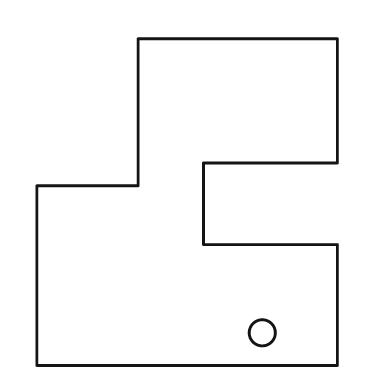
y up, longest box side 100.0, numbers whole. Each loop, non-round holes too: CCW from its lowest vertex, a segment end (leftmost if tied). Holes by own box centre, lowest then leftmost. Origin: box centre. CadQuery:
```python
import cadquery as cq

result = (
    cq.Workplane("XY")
    .moveTo(-46.0, -50.0)
    .lineTo(46.0, -50.0)
    .lineTo(46.0, -13.0)
    .lineTo(5.0, -13.0)
    .lineTo(5.0, 12.0)
    .lineTo(46.0, 12.0)
    .lineTo(46.0, 50.0)
    .lineTo(-15.0, 50.0)
    .lineTo(-15.0, 5.0)
    .lineTo(-46.0, 5.0)
    .close()
    .moveTo(23.0, -40.0)
    .circle(4.0)
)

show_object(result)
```